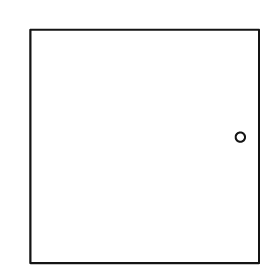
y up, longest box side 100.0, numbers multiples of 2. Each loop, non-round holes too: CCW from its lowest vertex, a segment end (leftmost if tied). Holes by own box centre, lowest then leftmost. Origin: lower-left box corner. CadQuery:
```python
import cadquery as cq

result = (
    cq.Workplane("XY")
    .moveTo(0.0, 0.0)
    .lineTo(98.0, 0.0)
    .lineTo(98.0, 100.0)
    .lineTo(0.0, 100.0)
    .close()
    .moveTo(90.0, 54.0)
    .circle(2.0)
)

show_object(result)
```